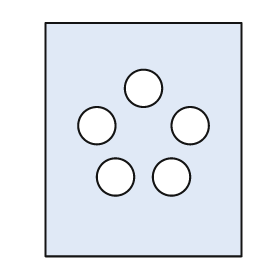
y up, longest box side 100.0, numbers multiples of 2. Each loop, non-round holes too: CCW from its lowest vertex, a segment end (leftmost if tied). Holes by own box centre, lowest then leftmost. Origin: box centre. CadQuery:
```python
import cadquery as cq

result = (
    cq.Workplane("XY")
    .moveTo(-42.0, -50.0)
    .lineTo(42.0, -50.0)
    .lineTo(42.0, 50.0)
    .lineTo(-42.0, 50.0)
    .close()
    .moveTo(-12.0, -16.0)
    .circle(8.0)
    .moveTo(12.0, -16.0)
    .circle(8.0)
    .moveTo(-20.0, 6.0)
    .circle(8.0)
    .moveTo(20.0, 6.0)
    .circle(8.0)
    .moveTo(0.0, 22.0)
    .circle(8.0)
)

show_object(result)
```